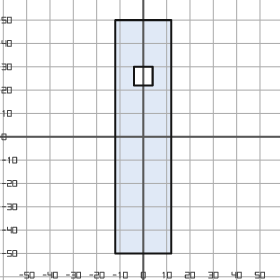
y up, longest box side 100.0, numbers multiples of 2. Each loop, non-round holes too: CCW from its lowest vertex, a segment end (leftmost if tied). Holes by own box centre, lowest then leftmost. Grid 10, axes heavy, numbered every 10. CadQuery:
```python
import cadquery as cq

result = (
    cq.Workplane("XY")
    .moveTo(-12.0, -50.0)
    .lineTo(12.0, -50.0)
    .lineTo(12.0, 50.0)
    .lineTo(-12.0, 50.0)
    .close()
    .moveTo(-4.0, 22.0)
    .lineTo(4.0, 22.0)
    .lineTo(4.0, 30.0)
    .lineTo(-4.0, 30.0)
    .close()
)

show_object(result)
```